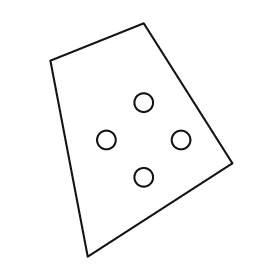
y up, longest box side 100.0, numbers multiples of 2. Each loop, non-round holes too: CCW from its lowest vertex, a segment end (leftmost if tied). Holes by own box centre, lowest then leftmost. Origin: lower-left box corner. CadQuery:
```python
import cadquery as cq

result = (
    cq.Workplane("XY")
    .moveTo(16.0, 0.0)
    .lineTo(78.0, 40.0)
    .lineTo(40.0, 100.0)
    .lineTo(0.0, 84.0)
    .close()
    .moveTo(40.0, 34.0)
    .circle(4.0)
    .moveTo(24.0, 50.0)
    .circle(4.0)
    .moveTo(56.0, 50.0)
    .circle(4.0)
    .moveTo(40.0, 66.0)
    .circle(4.0)
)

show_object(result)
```